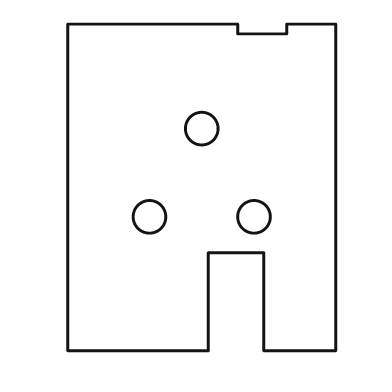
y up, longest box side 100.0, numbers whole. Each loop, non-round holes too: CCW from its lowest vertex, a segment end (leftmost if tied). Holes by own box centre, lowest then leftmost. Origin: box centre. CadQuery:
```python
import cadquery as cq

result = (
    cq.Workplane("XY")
    .moveTo(-41.0, -50.0)
    .lineTo(2.0, -50.0)
    .lineTo(2.0, -20.0)
    .lineTo(19.0, -20.0)
    .lineTo(19.0, -50.0)
    .lineTo(41.0, -50.0)
    .lineTo(41.0, 50.0)
    .lineTo(26.0, 50.0)
    .lineTo(26.0, 47.0)
    .lineTo(11.0, 47.0)
    .lineTo(11.0, 50.0)
    .lineTo(-41.0, 50.0)
    .close()
    .moveTo(-16.0, -9.0)
    .circle(5.0)
    .moveTo(16.0, -9.0)
    .circle(5.0)
    .moveTo(0.0, 18.0)
    .circle(5.0)
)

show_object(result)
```